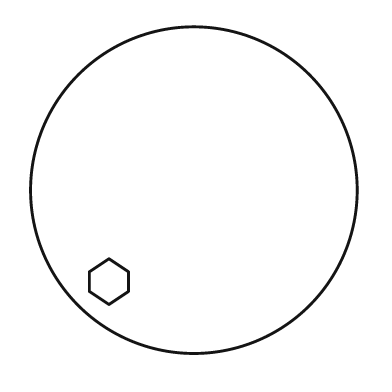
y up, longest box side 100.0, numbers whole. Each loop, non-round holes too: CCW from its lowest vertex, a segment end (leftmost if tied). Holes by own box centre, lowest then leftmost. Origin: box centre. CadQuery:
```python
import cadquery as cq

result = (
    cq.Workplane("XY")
    .moveTo(0.0, 0.0)
    .circle(50.0)
    .moveTo(-26.0, -35.0)
    .lineTo(-20.0, -31.0)
    .lineTo(-20.0, -25.0)
    .lineTo(-26.0, -21.0)
    .lineTo(-32.0, -25.0)
    .lineTo(-32.0, -31.0)
    .close()
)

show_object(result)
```